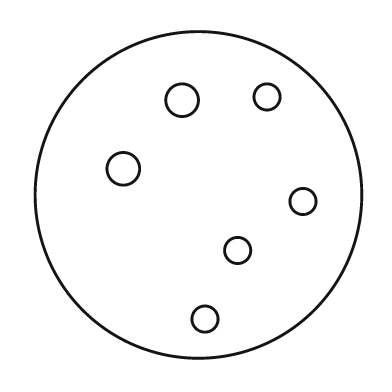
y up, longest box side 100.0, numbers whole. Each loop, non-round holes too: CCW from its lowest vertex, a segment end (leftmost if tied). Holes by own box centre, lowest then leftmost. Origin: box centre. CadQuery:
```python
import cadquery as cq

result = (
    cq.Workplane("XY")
    .moveTo(0.0, 0.0)
    .circle(50.0)
    .moveTo(2.0, -38.0)
    .circle(4.0)
    .moveTo(12.0, -17.0)
    .circle(4.0)
    .moveTo(32.0, -2.0)
    .circle(4.0)
    .moveTo(-23.0, 8.0)
    .circle(5.0)
    .moveTo(-5.0, 29.0)
    .circle(5.0)
    .moveTo(21.0, 30.0)
    .circle(4.0)
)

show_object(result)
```